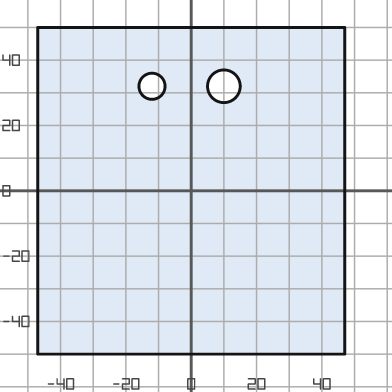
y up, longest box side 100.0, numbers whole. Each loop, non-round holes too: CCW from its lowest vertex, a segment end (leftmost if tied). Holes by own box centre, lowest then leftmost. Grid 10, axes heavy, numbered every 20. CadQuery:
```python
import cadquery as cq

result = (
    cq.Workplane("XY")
    .moveTo(-47.0, -50.0)
    .lineTo(47.0, -50.0)
    .lineTo(47.0, 50.0)
    .lineTo(-47.0, 50.0)
    .close()
    .moveTo(-12.0, 32.0)
    .circle(4.0)
    .moveTo(10.0, 32.0)
    .circle(5.0)
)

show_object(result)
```